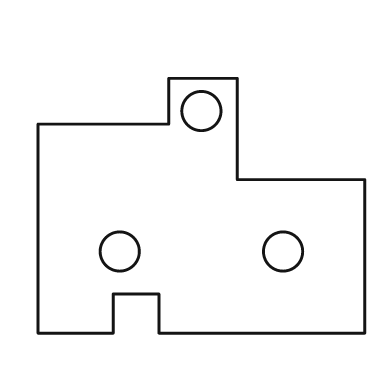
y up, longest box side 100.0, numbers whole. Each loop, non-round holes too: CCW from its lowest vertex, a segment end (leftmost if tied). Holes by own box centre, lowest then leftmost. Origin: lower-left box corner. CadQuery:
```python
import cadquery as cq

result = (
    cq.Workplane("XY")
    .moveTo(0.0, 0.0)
    .lineTo(23.0, 0.0)
    .lineTo(23.0, 12.0)
    .lineTo(37.0, 12.0)
    .lineTo(37.0, 0.0)
    .lineTo(100.0, 0.0)
    .lineTo(100.0, 47.0)
    .lineTo(61.0, 47.0)
    .lineTo(61.0, 78.0)
    .lineTo(40.0, 78.0)
    .lineTo(40.0, 64.0)
    .lineTo(0.0, 64.0)
    .close()
    .moveTo(25.0, 25.0)
    .circle(6.0)
    .moveTo(75.0, 25.0)
    .circle(6.0)
    .moveTo(50.0, 68.0)
    .circle(6.0)
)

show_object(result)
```